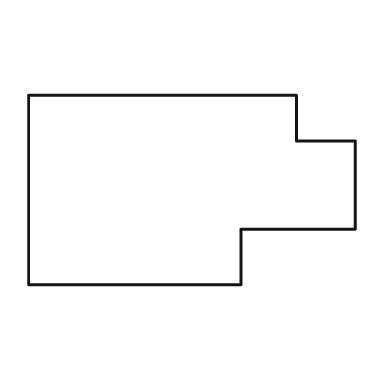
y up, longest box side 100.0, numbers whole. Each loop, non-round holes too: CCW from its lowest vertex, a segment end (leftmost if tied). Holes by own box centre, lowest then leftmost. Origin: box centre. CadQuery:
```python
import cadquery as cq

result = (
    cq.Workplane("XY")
    .moveTo(-50.0, -29.0)
    .lineTo(15.0, -29.0)
    .lineTo(15.0, -12.0)
    .lineTo(50.0, -12.0)
    .lineTo(50.0, 15.0)
    .lineTo(32.0, 15.0)
    .lineTo(32.0, 29.0)
    .lineTo(-50.0, 29.0)
    .close()
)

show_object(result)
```